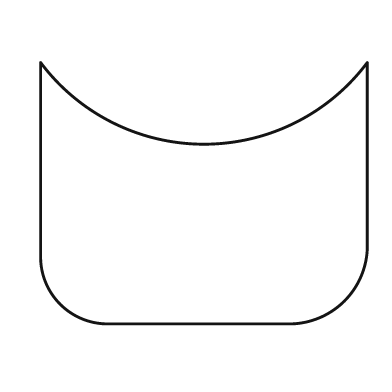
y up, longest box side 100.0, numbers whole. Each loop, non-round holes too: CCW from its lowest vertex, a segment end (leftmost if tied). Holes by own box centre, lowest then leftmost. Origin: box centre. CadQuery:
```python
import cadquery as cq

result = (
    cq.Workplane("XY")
    .moveTo(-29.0, -40.0)
    .lineTo(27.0, -40.0)
    .threePointArc((43.0, -33.0), (50.0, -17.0))
    .lineTo(50.0, 40.0)
    .threePointArc((0.0, 15.0), (-50.0, 40.0))
    .lineTo(-50.0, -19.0)
    .threePointArc((-44.0, -34.0), (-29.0, -40.0))
    .close()
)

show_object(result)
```